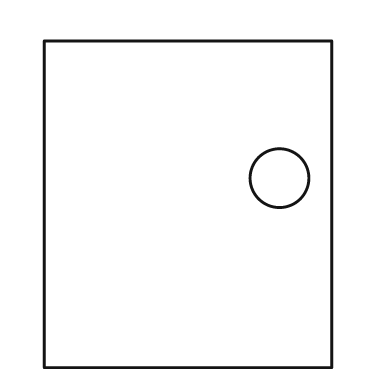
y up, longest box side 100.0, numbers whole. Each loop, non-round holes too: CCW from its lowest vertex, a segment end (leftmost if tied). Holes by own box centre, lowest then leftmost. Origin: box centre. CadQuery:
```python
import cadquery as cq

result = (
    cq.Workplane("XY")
    .moveTo(-44.0, -50.0)
    .lineTo(44.0, -50.0)
    .lineTo(44.0, 50.0)
    .lineTo(-44.0, 50.0)
    .close()
    .moveTo(28.0, 8.0)
    .circle(9.0)
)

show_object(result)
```